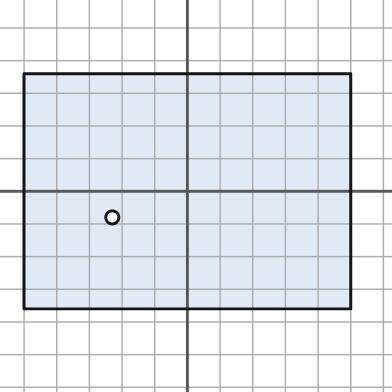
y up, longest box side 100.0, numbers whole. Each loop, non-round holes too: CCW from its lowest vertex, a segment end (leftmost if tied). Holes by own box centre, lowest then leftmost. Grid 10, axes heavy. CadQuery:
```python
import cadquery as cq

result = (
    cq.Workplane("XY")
    .moveTo(-50.0, -36.0)
    .lineTo(50.0, -36.0)
    .lineTo(50.0, 36.0)
    .lineTo(-50.0, 36.0)
    .close()
    .moveTo(-23.0, -8.0)
    .circle(2.0)
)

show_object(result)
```